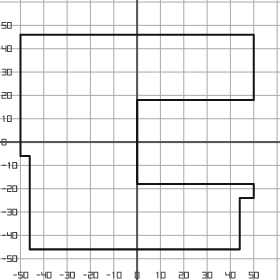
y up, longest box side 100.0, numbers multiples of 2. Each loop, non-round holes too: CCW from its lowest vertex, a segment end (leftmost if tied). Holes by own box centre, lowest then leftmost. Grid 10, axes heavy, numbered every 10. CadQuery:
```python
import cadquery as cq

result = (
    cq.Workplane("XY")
    .moveTo(-46.0, -46.0)
    .lineTo(44.0, -46.0)
    .lineTo(44.0, -24.0)
    .lineTo(50.0, -24.0)
    .lineTo(50.0, -18.0)
    .lineTo(0.0, -18.0)
    .lineTo(0.0, 18.0)
    .lineTo(50.0, 18.0)
    .lineTo(50.0, 46.0)
    .lineTo(-50.0, 46.0)
    .lineTo(-50.0, -6.0)
    .lineTo(-46.0, -6.0)
    .close()
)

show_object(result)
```